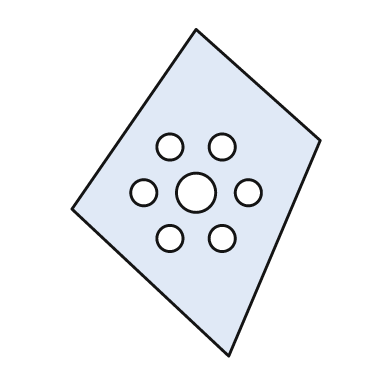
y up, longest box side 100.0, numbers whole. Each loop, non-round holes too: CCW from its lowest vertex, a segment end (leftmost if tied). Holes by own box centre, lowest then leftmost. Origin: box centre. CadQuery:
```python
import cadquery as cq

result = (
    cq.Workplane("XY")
    .moveTo(10.0, -50.0)
    .lineTo(38.0, 16.0)
    .lineTo(0.0, 50.0)
    .lineTo(-38.0, -5.0)
    .close()
    .moveTo(-8.0, -14.0)
    .circle(4.0)
    .moveTo(8.0, -14.0)
    .circle(4.0)
    .moveTo(-16.0, 0.0)
    .circle(4.0)
    .moveTo(0.0, 0.0)
    .circle(6.0)
    .moveTo(16.0, 0.0)
    .circle(4.0)
    .moveTo(-8.0, 14.0)
    .circle(4.0)
    .moveTo(8.0, 14.0)
    .circle(4.0)
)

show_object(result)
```